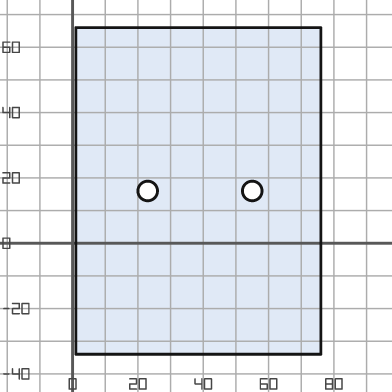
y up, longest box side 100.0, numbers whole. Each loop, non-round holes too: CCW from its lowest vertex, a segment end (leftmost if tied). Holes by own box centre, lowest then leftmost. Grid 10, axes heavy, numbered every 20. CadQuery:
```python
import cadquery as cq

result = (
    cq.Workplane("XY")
    .moveTo(1.0, -34.0)
    .lineTo(76.0, -34.0)
    .lineTo(76.0, 66.0)
    .lineTo(1.0, 66.0)
    .close()
    .moveTo(23.0, 16.0)
    .circle(3.0)
    .moveTo(55.0, 16.0)
    .circle(3.0)
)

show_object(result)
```